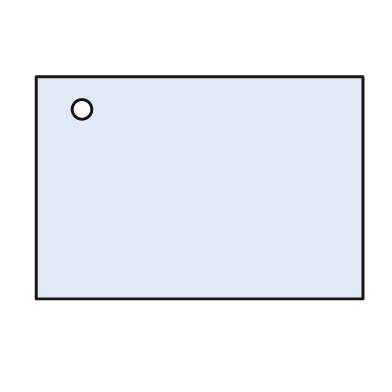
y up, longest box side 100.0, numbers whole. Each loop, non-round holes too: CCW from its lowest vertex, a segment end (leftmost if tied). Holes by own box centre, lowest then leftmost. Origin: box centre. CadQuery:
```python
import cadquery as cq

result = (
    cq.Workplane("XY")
    .moveTo(-50.0, -34.0)
    .lineTo(50.0, -34.0)
    .lineTo(50.0, 34.0)
    .lineTo(-50.0, 34.0)
    .close()
    .moveTo(-36.0, 24.0)
    .circle(3.0)
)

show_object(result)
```